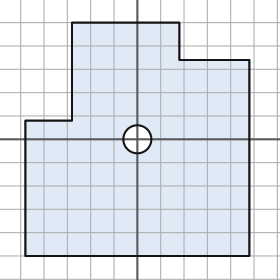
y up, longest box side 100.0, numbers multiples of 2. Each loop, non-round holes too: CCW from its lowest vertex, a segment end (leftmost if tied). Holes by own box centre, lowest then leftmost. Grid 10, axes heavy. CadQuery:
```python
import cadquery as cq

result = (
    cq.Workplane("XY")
    .moveTo(-48.0, -50.0)
    .lineTo(48.0, -50.0)
    .lineTo(48.0, 34.0)
    .lineTo(18.0, 34.0)
    .lineTo(18.0, 50.0)
    .lineTo(-28.0, 50.0)
    .lineTo(-28.0, 8.0)
    .lineTo(-48.0, 8.0)
    .close()
    .moveTo(0.0, 0.0)
    .circle(6.0)
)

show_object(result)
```